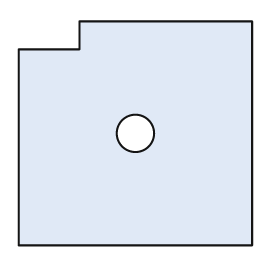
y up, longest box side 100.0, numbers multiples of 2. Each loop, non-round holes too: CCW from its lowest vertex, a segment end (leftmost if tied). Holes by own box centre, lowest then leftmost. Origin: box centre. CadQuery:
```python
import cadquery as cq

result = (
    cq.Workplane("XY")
    .moveTo(-50.0, -48.0)
    .lineTo(50.0, -48.0)
    .lineTo(50.0, 48.0)
    .lineTo(-24.0, 48.0)
    .lineTo(-24.0, 36.0)
    .lineTo(-50.0, 36.0)
    .close()
    .moveTo(0.0, 0.0)
    .circle(8.0)
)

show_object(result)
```